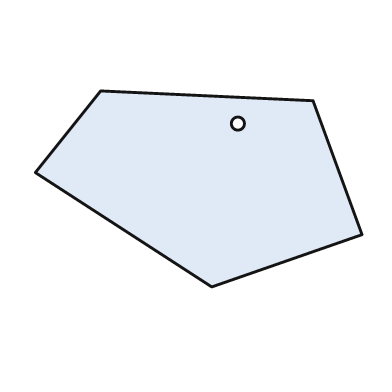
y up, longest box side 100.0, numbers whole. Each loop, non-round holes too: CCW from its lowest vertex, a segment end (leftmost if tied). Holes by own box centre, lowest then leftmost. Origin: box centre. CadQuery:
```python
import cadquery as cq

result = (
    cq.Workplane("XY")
    .moveTo(4.0, -30.0)
    .lineTo(50.0, -14.0)
    .lineTo(35.0, 27.0)
    .lineTo(-30.0, 30.0)
    .lineTo(-50.0, 5.0)
    .close()
    .moveTo(12.0, 20.0)
    .circle(2.0)
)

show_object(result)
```